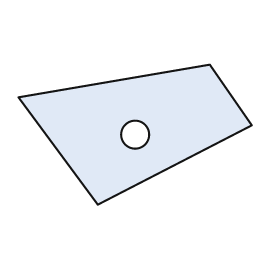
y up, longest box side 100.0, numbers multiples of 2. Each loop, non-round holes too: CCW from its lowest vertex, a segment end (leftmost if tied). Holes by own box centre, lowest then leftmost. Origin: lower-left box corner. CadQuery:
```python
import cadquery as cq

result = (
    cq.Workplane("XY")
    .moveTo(34.0, 0.0)
    .lineTo(100.0, 34.0)
    .lineTo(82.0, 60.0)
    .lineTo(0.0, 46.0)
    .close()
    .moveTo(50.0, 30.0)
    .circle(6.0)
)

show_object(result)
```